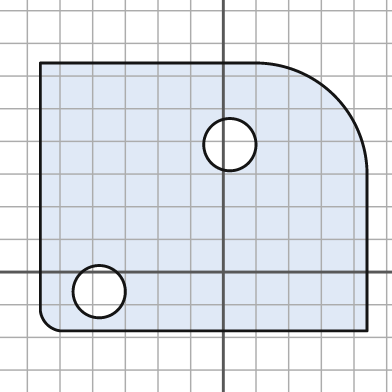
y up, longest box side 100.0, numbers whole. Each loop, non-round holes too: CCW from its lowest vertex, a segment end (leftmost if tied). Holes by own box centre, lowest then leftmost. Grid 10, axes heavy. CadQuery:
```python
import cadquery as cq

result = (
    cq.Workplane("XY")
    .moveTo(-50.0, -18.0)
    .lineTo(44.0, -18.0)
    .lineTo(44.0, 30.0)
    .threePointArc((34.0, 54.0), (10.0, 64.0))
    .lineTo(-56.0, 64.0)
    .lineTo(-56.0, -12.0)
    .threePointArc((-54.0, -16.0), (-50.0, -18.0))
    .close()
    .moveTo(-38.0, -6.0)
    .circle(8.0)
    .moveTo(2.0, 39.0)
    .circle(8.0)
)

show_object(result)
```